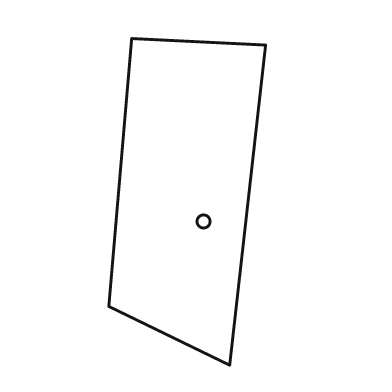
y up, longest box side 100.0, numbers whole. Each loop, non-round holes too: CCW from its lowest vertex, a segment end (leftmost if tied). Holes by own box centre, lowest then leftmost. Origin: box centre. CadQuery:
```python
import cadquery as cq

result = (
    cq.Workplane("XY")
    .moveTo(13.0, -50.0)
    .lineTo(24.0, 48.0)
    .lineTo(-17.0, 50.0)
    .lineTo(-24.0, -32.0)
    .close()
    .moveTo(5.0, -6.0)
    .circle(2.0)
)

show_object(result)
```